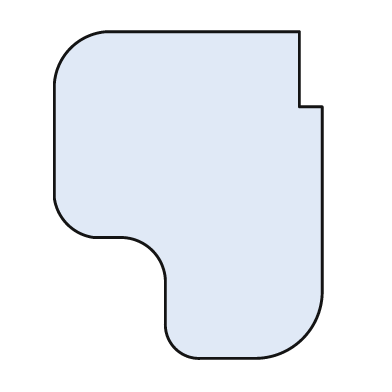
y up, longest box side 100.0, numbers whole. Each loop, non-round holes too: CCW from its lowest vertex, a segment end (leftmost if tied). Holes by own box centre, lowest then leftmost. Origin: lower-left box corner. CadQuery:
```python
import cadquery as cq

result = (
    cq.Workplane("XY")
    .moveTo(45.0, 0.0)
    .lineTo(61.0, 0.0)
    .threePointArc((76.0, 6.0), (82.0, 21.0))
    .lineTo(82.0, 77.0)
    .lineTo(75.0, 77.0)
    .lineTo(75.0, 100.0)
    .lineTo(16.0, 100.0)
    .threePointArc((5.0, 95.0), (0.0, 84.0))
    .lineTo(0.0, 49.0)
    .threePointArc((4.0, 41.0), (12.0, 37.0))
    .lineTo(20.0, 37.0)
    .threePointArc((30.0, 33.0), (34.0, 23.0))
    .lineTo(34.0, 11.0)
    .threePointArc((37.0, 3.0), (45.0, 0.0))
    .close()
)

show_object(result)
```